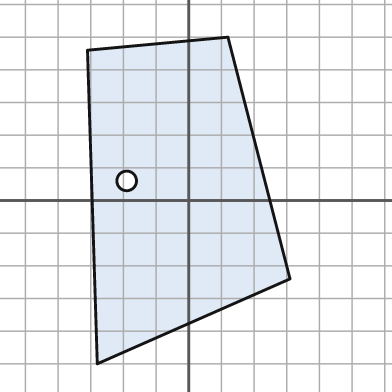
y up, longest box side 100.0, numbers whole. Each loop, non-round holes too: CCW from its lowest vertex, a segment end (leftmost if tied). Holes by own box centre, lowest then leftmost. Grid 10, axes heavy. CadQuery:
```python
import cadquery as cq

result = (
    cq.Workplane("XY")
    .moveTo(-28.0, -50.0)
    .lineTo(31.0, -24.0)
    .lineTo(12.0, 50.0)
    .lineTo(-31.0, 46.0)
    .close()
    .moveTo(-19.0, 6.0)
    .circle(3.0)
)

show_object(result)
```